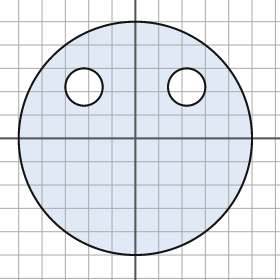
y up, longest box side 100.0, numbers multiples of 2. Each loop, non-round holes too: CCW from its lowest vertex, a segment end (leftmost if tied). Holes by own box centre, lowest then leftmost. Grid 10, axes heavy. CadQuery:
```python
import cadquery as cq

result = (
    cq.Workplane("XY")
    .moveTo(0.0, 0.0)
    .circle(50.0)
    .moveTo(-22.0, 22.0)
    .circle(8.0)
    .moveTo(22.0, 22.0)
    .circle(8.0)
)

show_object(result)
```